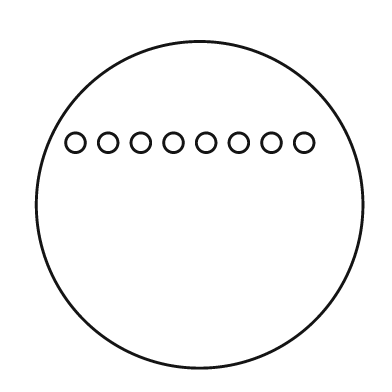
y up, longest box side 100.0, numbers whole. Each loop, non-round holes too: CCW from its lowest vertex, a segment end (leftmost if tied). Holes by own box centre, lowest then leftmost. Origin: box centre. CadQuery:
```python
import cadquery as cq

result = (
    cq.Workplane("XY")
    .moveTo(0.0, 0.0)
    .circle(50.0)
    .moveTo(-38.0, 19.0)
    .circle(3.0)
    .moveTo(-28.0, 19.0)
    .circle(3.0)
    .moveTo(-18.0, 19.0)
    .circle(3.0)
    .moveTo(-8.0, 19.0)
    .circle(3.0)
    .moveTo(2.0, 19.0)
    .circle(3.0)
    .moveTo(12.0, 19.0)
    .circle(3.0)
    .moveTo(22.0, 19.0)
    .circle(3.0)
    .moveTo(32.0, 19.0)
    .circle(3.0)
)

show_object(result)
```